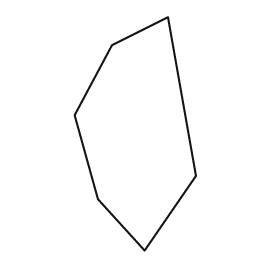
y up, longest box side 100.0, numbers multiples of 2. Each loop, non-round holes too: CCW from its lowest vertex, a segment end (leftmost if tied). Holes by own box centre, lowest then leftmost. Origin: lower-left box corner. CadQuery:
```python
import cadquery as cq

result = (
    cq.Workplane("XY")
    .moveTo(30.0, 0.0)
    .lineTo(52.0, 32.0)
    .lineTo(40.0, 100.0)
    .lineTo(16.0, 88.0)
    .lineTo(0.0, 58.0)
    .lineTo(10.0, 22.0)
    .close()
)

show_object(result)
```